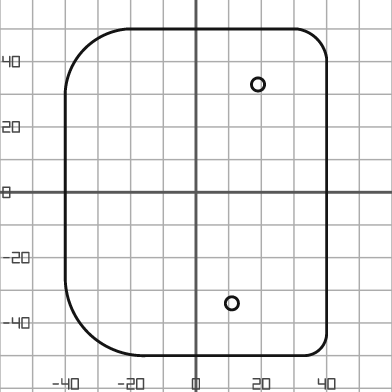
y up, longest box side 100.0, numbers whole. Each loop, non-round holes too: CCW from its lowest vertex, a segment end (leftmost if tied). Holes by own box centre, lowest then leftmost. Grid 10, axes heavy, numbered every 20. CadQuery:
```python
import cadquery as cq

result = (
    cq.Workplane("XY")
    .moveTo(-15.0, -50.0)
    .lineTo(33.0, -50.0)
    .threePointArc((38.0, -48.0), (40.0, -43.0))
    .lineTo(40.0, 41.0)
    .threePointArc((37.0, 47.0), (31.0, 50.0))
    .lineTo(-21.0, 50.0)
    .threePointArc((-34.0, 44.0), (-40.0, 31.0))
    .lineTo(-40.0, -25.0)
    .threePointArc((-33.0, -43.0), (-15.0, -50.0))
    .close()
    .moveTo(11.0, -34.0)
    .circle(2.0)
    .moveTo(19.0, 33.0)
    .circle(2.0)
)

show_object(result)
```